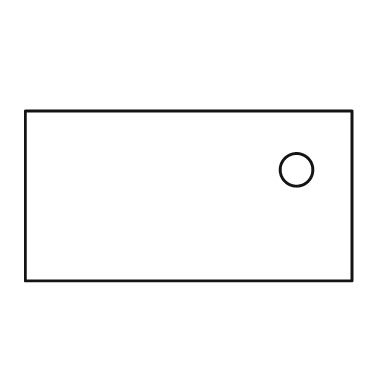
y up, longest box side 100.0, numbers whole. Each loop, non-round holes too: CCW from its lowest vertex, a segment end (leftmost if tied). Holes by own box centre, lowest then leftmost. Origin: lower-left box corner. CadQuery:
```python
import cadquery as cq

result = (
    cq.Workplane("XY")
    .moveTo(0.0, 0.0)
    .lineTo(100.0, 0.0)
    .lineTo(100.0, 52.0)
    .lineTo(0.0, 52.0)
    .close()
    .moveTo(83.0, 34.0)
    .circle(5.0)
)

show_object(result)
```